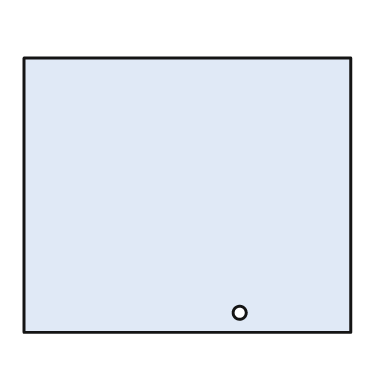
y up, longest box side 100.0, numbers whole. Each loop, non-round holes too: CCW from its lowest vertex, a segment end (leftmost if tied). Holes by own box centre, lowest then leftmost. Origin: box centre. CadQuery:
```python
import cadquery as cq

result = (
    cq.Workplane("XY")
    .moveTo(-50.0, -42.0)
    .lineTo(50.0, -42.0)
    .lineTo(50.0, 42.0)
    .lineTo(-50.0, 42.0)
    .close()
    .moveTo(16.0, -36.0)
    .circle(2.0)
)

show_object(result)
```